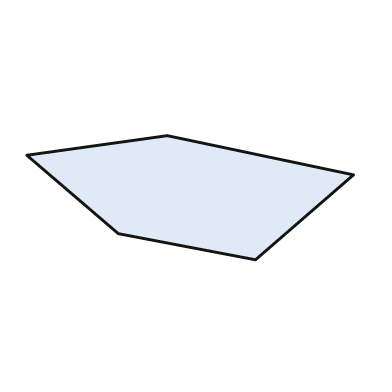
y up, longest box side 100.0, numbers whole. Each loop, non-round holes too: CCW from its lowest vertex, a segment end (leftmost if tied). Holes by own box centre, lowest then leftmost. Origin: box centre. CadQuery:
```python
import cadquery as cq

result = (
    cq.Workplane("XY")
    .moveTo(20.0, -19.0)
    .lineTo(50.0, 7.0)
    .lineTo(-7.0, 19.0)
    .lineTo(-50.0, 13.0)
    .lineTo(-22.0, -11.0)
    .close()
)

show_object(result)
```